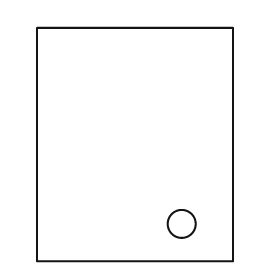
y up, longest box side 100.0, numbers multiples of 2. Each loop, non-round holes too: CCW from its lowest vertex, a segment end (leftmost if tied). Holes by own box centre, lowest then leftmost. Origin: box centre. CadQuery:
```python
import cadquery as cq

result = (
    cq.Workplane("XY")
    .moveTo(-42.0, -50.0)
    .lineTo(42.0, -50.0)
    .lineTo(42.0, 50.0)
    .lineTo(-42.0, 50.0)
    .close()
    .moveTo(20.0, -34.0)
    .circle(6.0)
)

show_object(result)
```